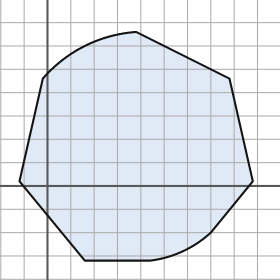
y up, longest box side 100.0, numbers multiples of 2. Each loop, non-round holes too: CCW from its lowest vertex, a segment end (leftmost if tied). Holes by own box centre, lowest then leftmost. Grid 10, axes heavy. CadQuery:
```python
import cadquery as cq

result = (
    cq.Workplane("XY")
    .moveTo(16.0, -32.0)
    .lineTo(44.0, -32.0)
    .threePointArc((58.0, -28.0), (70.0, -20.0))
    .lineTo(88.0, 2.0)
    .lineTo(78.0, 46.0)
    .lineTo(38.0, 66.0)
    .threePointArc((16.0, 60.0), (-2.0, 46.0))
    .lineTo(-12.0, 2.0)
    .close()
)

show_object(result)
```